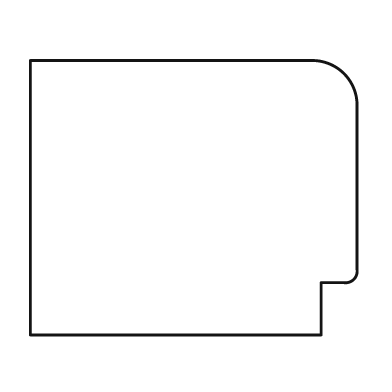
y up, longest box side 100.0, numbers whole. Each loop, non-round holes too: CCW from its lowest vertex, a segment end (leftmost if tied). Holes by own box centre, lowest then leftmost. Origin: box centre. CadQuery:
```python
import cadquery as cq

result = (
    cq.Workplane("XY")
    .moveTo(-50.0, -42.0)
    .lineTo(39.0, -42.0)
    .lineTo(39.0, -26.0)
    .lineTo(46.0, -26.0)
    .threePointArc((49.0, -25.0), (50.0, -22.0))
    .lineTo(50.0, 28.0)
    .threePointArc((46.0, 38.0), (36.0, 42.0))
    .lineTo(-50.0, 42.0)
    .close()
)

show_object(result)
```